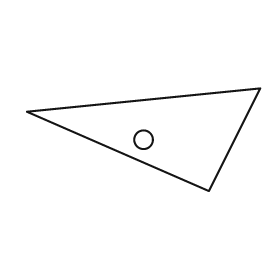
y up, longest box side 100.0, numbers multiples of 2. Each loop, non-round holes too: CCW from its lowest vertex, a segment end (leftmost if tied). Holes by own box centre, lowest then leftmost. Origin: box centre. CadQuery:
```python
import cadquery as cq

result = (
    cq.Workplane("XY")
    .moveTo(28.0, -22.0)
    .lineTo(50.0, 22.0)
    .lineTo(-50.0, 12.0)
    .close()
    .moveTo(0.0, 0.0)
    .circle(4.0)
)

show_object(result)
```